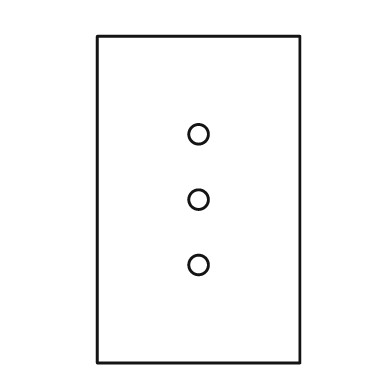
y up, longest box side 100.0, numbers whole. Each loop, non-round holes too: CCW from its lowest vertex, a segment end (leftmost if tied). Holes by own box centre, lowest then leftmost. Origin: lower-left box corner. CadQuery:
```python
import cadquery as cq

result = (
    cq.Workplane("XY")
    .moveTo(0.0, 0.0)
    .lineTo(62.0, 0.0)
    .lineTo(62.0, 100.0)
    .lineTo(0.0, 100.0)
    .close()
    .moveTo(31.0, 30.0)
    .circle(3.0)
    .moveTo(31.0, 50.0)
    .circle(3.0)
    .moveTo(31.0, 70.0)
    .circle(3.0)
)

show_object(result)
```